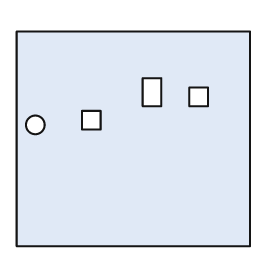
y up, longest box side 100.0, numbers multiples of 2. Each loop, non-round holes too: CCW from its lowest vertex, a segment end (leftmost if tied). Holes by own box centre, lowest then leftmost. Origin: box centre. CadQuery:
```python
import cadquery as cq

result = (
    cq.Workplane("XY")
    .moveTo(-50.0, -46.0)
    .lineTo(50.0, -46.0)
    .lineTo(50.0, 46.0)
    .lineTo(-50.0, 46.0)
    .close()
    .moveTo(-42.0, 6.0)
    .circle(4.0)
    .moveTo(-22.0, 4.0)
    .lineTo(-14.0, 4.0)
    .lineTo(-14.0, 12.0)
    .lineTo(-22.0, 12.0)
    .close()
    .moveTo(24.0, 14.0)
    .lineTo(32.0, 14.0)
    .lineTo(32.0, 22.0)
    .lineTo(24.0, 22.0)
    .close()
    .moveTo(4.0, 14.0)
    .lineTo(12.0, 14.0)
    .lineTo(12.0, 26.0)
    .lineTo(4.0, 26.0)
    .close()
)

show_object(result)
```